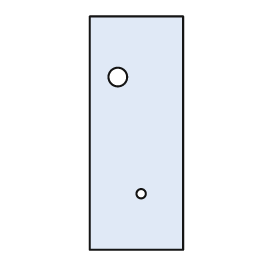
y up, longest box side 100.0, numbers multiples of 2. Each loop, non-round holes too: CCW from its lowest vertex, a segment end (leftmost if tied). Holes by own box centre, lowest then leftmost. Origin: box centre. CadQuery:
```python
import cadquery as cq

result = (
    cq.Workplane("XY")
    .moveTo(-20.0, -50.0)
    .lineTo(20.0, -50.0)
    .lineTo(20.0, 50.0)
    .lineTo(-20.0, 50.0)
    .close()
    .moveTo(2.0, -26.0)
    .circle(2.0)
    .moveTo(-8.0, 24.0)
    .circle(4.0)
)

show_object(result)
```